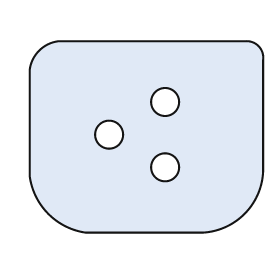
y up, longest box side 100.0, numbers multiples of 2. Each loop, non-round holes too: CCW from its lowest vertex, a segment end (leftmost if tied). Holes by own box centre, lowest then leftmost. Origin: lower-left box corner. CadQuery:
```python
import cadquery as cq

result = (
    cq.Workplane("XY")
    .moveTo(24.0, 0.0)
    .lineTo(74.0, 0.0)
    .threePointArc((92.0, 8.0), (100.0, 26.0))
    .lineTo(100.0, 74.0)
    .threePointArc((98.0, 80.0), (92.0, 82.0))
    .lineTo(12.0, 82.0)
    .threePointArc((4.0, 78.0), (0.0, 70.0))
    .lineTo(0.0, 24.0)
    .threePointArc((8.0, 8.0), (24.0, 0.0))
    .close()
    .moveTo(58.0, 28.0)
    .circle(6.0)
    .moveTo(34.0, 42.0)
    .circle(6.0)
    .moveTo(58.0, 56.0)
    .circle(6.0)
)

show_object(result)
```